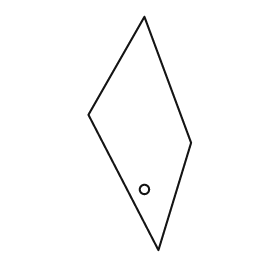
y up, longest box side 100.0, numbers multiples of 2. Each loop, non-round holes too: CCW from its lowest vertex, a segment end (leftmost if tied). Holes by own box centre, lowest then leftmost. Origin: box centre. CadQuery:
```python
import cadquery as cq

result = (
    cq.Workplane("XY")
    .moveTo(8.0, -50.0)
    .lineTo(22.0, -4.0)
    .lineTo(2.0, 50.0)
    .lineTo(-22.0, 8.0)
    .close()
    .moveTo(2.0, -24.0)
    .circle(2.0)
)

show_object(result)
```